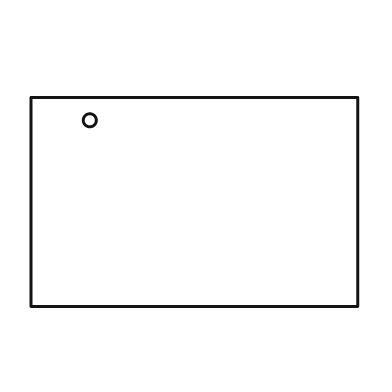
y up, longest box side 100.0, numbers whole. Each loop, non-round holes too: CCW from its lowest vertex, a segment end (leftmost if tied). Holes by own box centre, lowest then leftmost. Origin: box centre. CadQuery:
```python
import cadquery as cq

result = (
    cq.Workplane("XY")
    .moveTo(-50.0, -32.0)
    .lineTo(50.0, -32.0)
    .lineTo(50.0, 32.0)
    .lineTo(-50.0, 32.0)
    .close()
    .moveTo(-32.0, 25.0)
    .circle(2.0)
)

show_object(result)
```